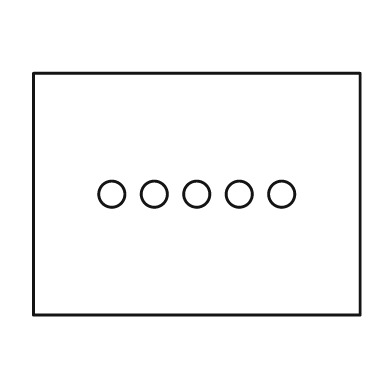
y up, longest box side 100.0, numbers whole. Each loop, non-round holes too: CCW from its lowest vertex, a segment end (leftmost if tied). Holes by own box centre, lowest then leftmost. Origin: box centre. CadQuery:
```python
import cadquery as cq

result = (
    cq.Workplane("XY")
    .moveTo(-50.0, -37.0)
    .lineTo(50.0, -37.0)
    .lineTo(50.0, 37.0)
    .lineTo(-50.0, 37.0)
    .close()
    .moveTo(-26.0, 0.0)
    .circle(4.0)
    .moveTo(-13.0, 0.0)
    .circle(4.0)
    .moveTo(0.0, 0.0)
    .circle(4.0)
    .moveTo(13.0, 0.0)
    .circle(4.0)
    .moveTo(26.0, 0.0)
    .circle(4.0)
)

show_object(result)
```